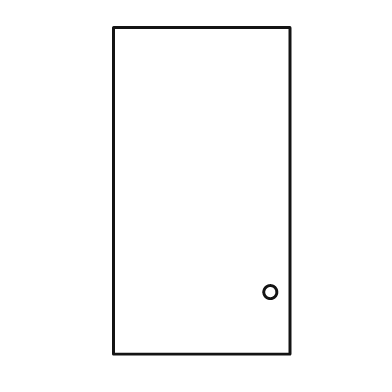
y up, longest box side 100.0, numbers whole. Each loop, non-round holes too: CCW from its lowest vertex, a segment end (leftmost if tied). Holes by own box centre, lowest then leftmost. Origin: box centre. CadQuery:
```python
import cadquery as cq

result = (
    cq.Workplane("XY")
    .moveTo(-27.0, -50.0)
    .lineTo(27.0, -50.0)
    .lineTo(27.0, 50.0)
    .lineTo(-27.0, 50.0)
    .close()
    .moveTo(21.0, -31.0)
    .circle(2.0)
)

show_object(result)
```